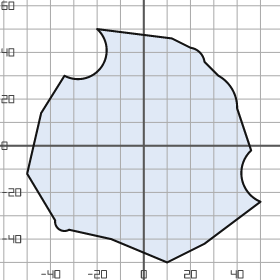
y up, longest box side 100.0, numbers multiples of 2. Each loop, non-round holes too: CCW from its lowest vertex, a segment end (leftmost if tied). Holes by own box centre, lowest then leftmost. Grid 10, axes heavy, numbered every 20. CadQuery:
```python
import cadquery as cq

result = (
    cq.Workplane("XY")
    .moveTo(10.0, -50.0)
    .lineTo(26.0, -42.0)
    .lineTo(50.0, -24.0)
    .threePointArc((42.0, -14.0), (46.0, -2.0))
    .lineTo(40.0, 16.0)
    .threePointArc((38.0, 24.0), (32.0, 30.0))
    .lineTo(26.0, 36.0)
    .threePointArc((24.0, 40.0), (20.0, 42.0))
    .lineTo(12.0, 46.0)
    .lineTo(-20.0, 50.0)
    .threePointArc((-18.0, 34.0), (-34.0, 30.0))
    .lineTo(-44.0, 14.0)
    .lineTo(-50.0, -12.0)
    .lineTo(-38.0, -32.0)
    .threePointArc((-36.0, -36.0), (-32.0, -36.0))
    .lineTo(-14.0, -40.0)
    .close()
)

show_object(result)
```